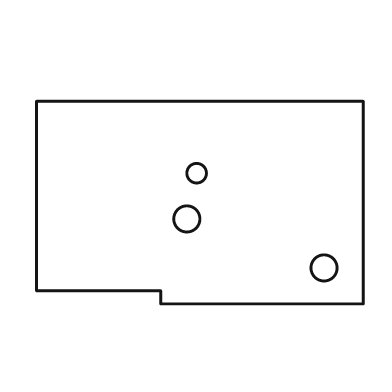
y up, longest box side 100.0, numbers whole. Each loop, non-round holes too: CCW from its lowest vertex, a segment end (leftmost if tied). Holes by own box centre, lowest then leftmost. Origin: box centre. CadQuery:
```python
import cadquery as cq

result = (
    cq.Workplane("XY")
    .moveTo(-12.0, -31.0)
    .lineTo(50.0, -31.0)
    .lineTo(50.0, 31.0)
    .lineTo(-50.0, 31.0)
    .lineTo(-50.0, -27.0)
    .lineTo(-12.0, -27.0)
    .close()
    .moveTo(38.0, -20.0)
    .circle(4.0)
    .moveTo(-4.0, -5.0)
    .circle(4.0)
    .moveTo(-1.0, 9.0)
    .circle(3.0)
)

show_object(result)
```